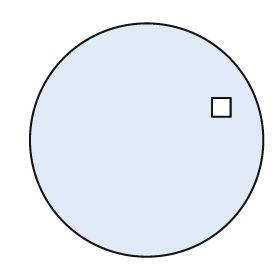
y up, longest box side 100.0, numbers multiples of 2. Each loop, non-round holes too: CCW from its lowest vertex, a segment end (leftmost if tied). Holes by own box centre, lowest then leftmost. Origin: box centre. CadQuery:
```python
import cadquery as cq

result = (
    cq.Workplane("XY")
    .moveTo(0.0, 0.0)
    .circle(50.0)
    .moveTo(28.0, 10.0)
    .lineTo(36.0, 10.0)
    .lineTo(36.0, 18.0)
    .lineTo(28.0, 18.0)
    .close()
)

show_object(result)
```